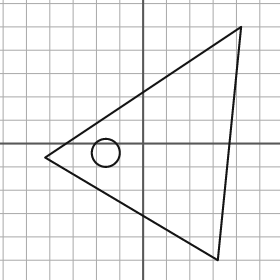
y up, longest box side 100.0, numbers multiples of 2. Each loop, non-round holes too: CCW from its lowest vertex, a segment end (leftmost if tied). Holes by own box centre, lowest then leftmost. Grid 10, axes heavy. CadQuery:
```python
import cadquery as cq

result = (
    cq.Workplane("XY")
    .moveTo(32.0, -50.0)
    .lineTo(42.0, 50.0)
    .lineTo(-42.0, -6.0)
    .close()
    .moveTo(-16.0, -4.0)
    .circle(6.0)
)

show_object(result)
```